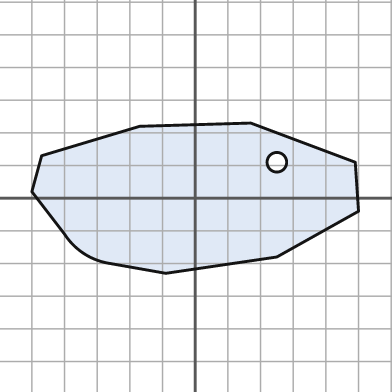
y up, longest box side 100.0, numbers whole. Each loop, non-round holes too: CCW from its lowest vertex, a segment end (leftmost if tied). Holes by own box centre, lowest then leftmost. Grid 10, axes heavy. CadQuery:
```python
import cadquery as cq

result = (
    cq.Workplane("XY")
    .moveTo(-9.0, -23.0)
    .lineTo(25.0, -18.0)
    .lineTo(50.0, -4.0)
    .lineTo(49.0, 11.0)
    .lineTo(17.0, 23.0)
    .lineTo(-17.0, 22.0)
    .lineTo(-47.0, 13.0)
    .lineTo(-50.0, 2.0)
    .lineTo(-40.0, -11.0)
    .threePointArc((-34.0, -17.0), (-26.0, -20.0))
    .close()
    .moveTo(25.0, 11.0)
    .circle(3.0)
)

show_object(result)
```